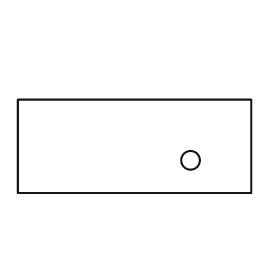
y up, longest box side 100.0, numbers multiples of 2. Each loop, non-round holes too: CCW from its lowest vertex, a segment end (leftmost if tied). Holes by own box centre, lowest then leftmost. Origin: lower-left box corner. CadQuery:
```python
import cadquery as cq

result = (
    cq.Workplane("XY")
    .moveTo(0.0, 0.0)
    .lineTo(100.0, 0.0)
    .lineTo(100.0, 40.0)
    .lineTo(0.0, 40.0)
    .close()
    .moveTo(74.0, 14.0)
    .circle(4.0)
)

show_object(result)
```